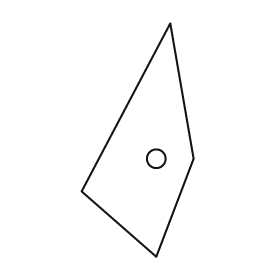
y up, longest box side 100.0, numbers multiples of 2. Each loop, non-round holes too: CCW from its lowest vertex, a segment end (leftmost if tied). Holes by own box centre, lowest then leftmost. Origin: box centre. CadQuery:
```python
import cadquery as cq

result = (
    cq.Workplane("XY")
    .moveTo(8.0, -50.0)
    .lineTo(24.0, -8.0)
    .lineTo(14.0, 50.0)
    .lineTo(-24.0, -22.0)
    .close()
    .moveTo(8.0, -8.0)
    .circle(4.0)
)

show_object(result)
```